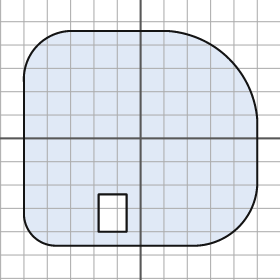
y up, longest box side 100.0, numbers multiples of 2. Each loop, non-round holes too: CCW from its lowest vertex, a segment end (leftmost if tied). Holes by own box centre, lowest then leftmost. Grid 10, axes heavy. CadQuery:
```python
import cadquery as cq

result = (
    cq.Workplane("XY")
    .moveTo(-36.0, -46.0)
    .lineTo(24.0, -46.0)
    .threePointArc((42.0, -38.0), (50.0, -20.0))
    .lineTo(50.0, 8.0)
    .threePointArc((38.0, 34.0), (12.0, 46.0))
    .lineTo(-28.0, 46.0)
    .threePointArc((-44.0, 40.0), (-50.0, 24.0))
    .lineTo(-50.0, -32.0)
    .threePointArc((-46.0, -42.0), (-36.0, -46.0))
    .close()
    .moveTo(-18.0, -40.0)
    .lineTo(-6.0, -40.0)
    .lineTo(-6.0, -24.0)
    .lineTo(-18.0, -24.0)
    .close()
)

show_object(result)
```